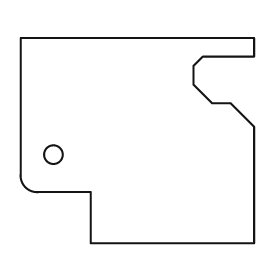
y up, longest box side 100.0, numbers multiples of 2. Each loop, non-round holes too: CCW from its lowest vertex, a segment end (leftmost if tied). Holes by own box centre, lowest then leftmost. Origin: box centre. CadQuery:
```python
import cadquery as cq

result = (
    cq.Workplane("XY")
    .moveTo(-20.0, -44.0)
    .lineTo(50.0, -44.0)
    .lineTo(50.0, 6.0)
    .lineTo(40.0, 16.0)
    .lineTo(32.0, 16.0)
    .lineTo(24.0, 24.0)
    .lineTo(24.0, 32.0)
    .lineTo(28.0, 36.0)
    .lineTo(50.0, 36.0)
    .lineTo(50.0, 44.0)
    .lineTo(-50.0, 44.0)
    .lineTo(-50.0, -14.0)
    .threePointArc((-48.0, -20.0), (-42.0, -22.0))
    .lineTo(-20.0, -22.0)
    .close()
    .moveTo(-36.0, -6.0)
    .circle(4.0)
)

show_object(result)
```